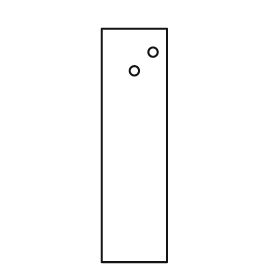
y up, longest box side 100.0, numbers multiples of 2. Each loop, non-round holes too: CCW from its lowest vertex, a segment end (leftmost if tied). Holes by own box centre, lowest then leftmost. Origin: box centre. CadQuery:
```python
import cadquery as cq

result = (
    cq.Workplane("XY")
    .moveTo(-14.0, -50.0)
    .lineTo(14.0, -50.0)
    .lineTo(14.0, 50.0)
    .lineTo(-14.0, 50.0)
    .close()
    .moveTo(0.0, 32.0)
    .circle(2.0)
    .moveTo(8.0, 40.0)
    .circle(2.0)
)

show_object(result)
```